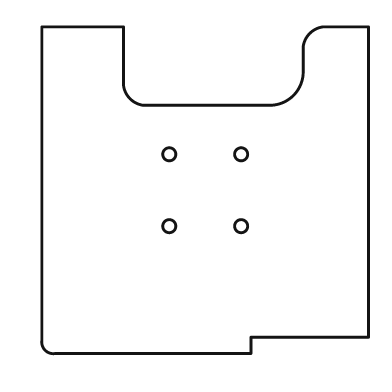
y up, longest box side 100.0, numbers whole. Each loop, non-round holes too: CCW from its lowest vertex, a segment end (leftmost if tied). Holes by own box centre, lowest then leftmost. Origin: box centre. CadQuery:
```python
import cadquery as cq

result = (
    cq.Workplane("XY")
    .moveTo(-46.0, -50.0)
    .lineTo(14.0, -50.0)
    .lineTo(14.0, -45.0)
    .lineTo(50.0, -45.0)
    .lineTo(50.0, 50.0)
    .lineTo(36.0, 50.0)
    .threePointArc((32.0, 48.0), (30.0, 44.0))
    .lineTo(30.0, 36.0)
    .threePointArc((27.0, 29.0), (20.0, 26.0))
    .lineTo(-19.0, 26.0)
    .threePointArc((-23.0, 28.0), (-25.0, 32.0))
    .lineTo(-25.0, 50.0)
    .lineTo(-50.0, 50.0)
    .lineTo(-50.0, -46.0)
    .threePointArc((-49.0, -49.0), (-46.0, -50.0))
    .close()
    .moveTo(-11.0, -11.0)
    .circle(2.0)
    .moveTo(11.0, -11.0)
    .circle(2.0)
    .moveTo(-11.0, 11.0)
    .circle(2.0)
    .moveTo(11.0, 11.0)
    .circle(2.0)
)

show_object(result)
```